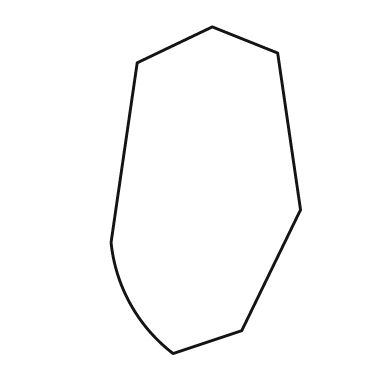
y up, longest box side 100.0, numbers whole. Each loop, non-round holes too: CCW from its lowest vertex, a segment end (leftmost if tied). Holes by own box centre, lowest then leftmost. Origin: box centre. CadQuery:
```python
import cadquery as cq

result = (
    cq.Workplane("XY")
    .moveTo(-10.0, -50.0)
    .lineTo(11.0, -43.0)
    .lineTo(29.0, -6.0)
    .lineTo(22.0, 42.0)
    .lineTo(2.0, 50.0)
    .lineTo(-21.0, 39.0)
    .lineTo(-29.0, -16.0)
    .threePointArc((-23.0, -35.0), (-10.0, -50.0))
    .close()
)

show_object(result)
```